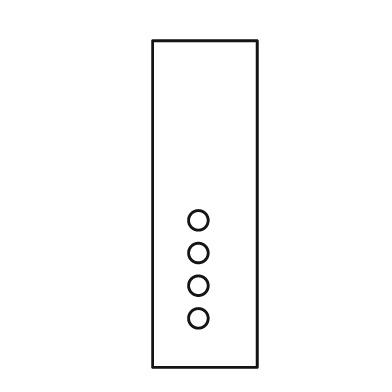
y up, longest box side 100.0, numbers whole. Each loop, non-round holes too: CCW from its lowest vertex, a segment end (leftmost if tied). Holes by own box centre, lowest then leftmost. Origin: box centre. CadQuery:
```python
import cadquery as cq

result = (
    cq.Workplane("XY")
    .moveTo(-16.0, -50.0)
    .lineTo(16.0, -50.0)
    .lineTo(16.0, 50.0)
    .lineTo(-16.0, 50.0)
    .close()
    .moveTo(-2.0, -35.0)
    .circle(3.0)
    .moveTo(-2.0, -25.0)
    .circle(3.0)
    .moveTo(-2.0, -15.0)
    .circle(3.0)
    .moveTo(-2.0, -5.0)
    .circle(3.0)
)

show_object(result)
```